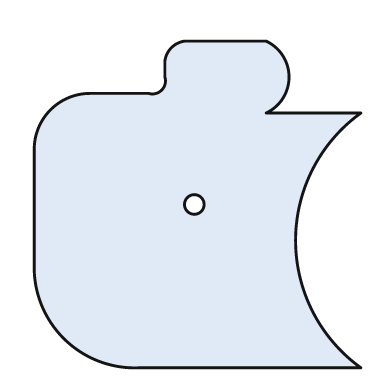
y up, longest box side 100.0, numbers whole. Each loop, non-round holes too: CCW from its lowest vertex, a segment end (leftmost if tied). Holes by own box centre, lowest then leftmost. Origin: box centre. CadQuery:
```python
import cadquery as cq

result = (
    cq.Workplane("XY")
    .moveTo(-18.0, -50.0)
    .lineTo(50.0, -50.0)
    .threePointArc((30.0, -11.0), (50.0, 28.0))
    .lineTo(21.0, 28.0)
    .threePointArc((28.0, 39.0), (21.0, 50.0))
    .lineTo(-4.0, 50.0)
    .threePointArc((-8.0, 48.0), (-10.0, 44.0))
    .lineTo(-10.0, 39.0)
    .threePointArc((-11.0, 35.0), (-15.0, 34.0))
    .lineTo(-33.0, 34.0)
    .threePointArc((-45.0, 29.0), (-50.0, 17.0))
    .lineTo(-50.0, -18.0)
    .threePointArc((-41.0, -41.0), (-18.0, -50.0))
    .close()
    .moveTo(-1.0, 0.0)
    .circle(3.0)
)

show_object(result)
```